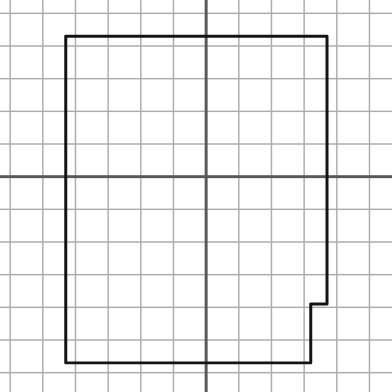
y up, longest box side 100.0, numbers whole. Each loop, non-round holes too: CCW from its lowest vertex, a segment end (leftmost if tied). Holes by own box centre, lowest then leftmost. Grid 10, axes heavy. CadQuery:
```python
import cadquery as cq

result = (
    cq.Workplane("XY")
    .moveTo(-43.0, -57.0)
    .lineTo(32.0, -57.0)
    .lineTo(32.0, -39.0)
    .lineTo(37.0, -39.0)
    .lineTo(37.0, 43.0)
    .lineTo(-43.0, 43.0)
    .close()
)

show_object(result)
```